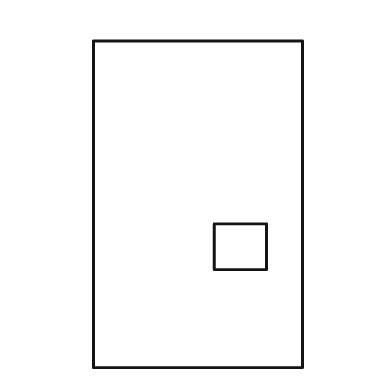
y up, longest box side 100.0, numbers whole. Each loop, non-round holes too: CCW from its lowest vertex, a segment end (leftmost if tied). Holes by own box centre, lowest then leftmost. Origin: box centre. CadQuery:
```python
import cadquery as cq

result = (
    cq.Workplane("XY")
    .moveTo(-32.0, -50.0)
    .lineTo(32.0, -50.0)
    .lineTo(32.0, 50.0)
    .lineTo(-32.0, 50.0)
    .close()
    .moveTo(5.0, -20.0)
    .lineTo(21.0, -20.0)
    .lineTo(21.0, -6.0)
    .lineTo(5.0, -6.0)
    .close()
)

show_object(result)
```